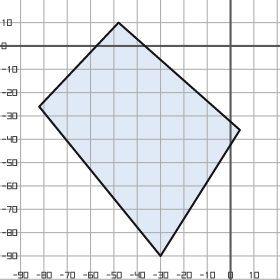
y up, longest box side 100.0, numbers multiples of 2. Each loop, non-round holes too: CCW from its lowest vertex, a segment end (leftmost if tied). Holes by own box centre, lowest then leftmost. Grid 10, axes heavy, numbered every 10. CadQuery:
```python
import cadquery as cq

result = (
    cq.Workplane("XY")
    .moveTo(-30.0, -90.0)
    .lineTo(4.0, -36.0)
    .lineTo(-48.0, 10.0)
    .lineTo(-82.0, -26.0)
    .close()
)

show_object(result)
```